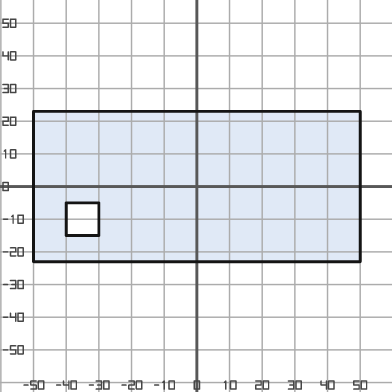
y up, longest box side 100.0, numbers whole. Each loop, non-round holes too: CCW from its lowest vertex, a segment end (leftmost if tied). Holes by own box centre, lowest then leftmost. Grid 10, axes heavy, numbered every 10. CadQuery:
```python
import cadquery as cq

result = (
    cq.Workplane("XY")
    .moveTo(-50.0, -23.0)
    .lineTo(50.0, -23.0)
    .lineTo(50.0, 23.0)
    .lineTo(-50.0, 23.0)
    .close()
    .moveTo(-40.0, -15.0)
    .lineTo(-30.0, -15.0)
    .lineTo(-30.0, -5.0)
    .lineTo(-40.0, -5.0)
    .close()
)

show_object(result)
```